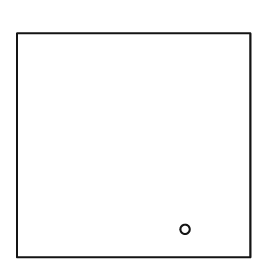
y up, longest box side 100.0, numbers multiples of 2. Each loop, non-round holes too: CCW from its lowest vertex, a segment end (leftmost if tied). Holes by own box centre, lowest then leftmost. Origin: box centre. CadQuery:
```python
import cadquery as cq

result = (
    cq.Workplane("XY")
    .moveTo(-50.0, -48.0)
    .lineTo(50.0, -48.0)
    .lineTo(50.0, 48.0)
    .lineTo(-50.0, 48.0)
    .close()
    .moveTo(22.0, -36.0)
    .circle(2.0)
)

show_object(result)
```